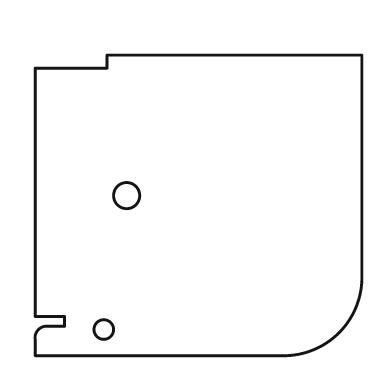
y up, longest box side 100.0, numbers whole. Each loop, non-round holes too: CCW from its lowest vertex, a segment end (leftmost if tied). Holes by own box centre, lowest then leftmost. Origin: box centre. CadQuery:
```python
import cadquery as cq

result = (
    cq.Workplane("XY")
    .moveTo(-50.0, -46.0)
    .lineTo(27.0, -46.0)
    .threePointArc((43.0, -39.0), (50.0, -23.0))
    .lineTo(50.0, 46.0)
    .lineTo(-28.0, 46.0)
    .lineTo(-28.0, 42.0)
    .lineTo(-50.0, 42.0)
    .lineTo(-50.0, -34.0)
    .lineTo(-41.0, -34.0)
    .lineTo(-41.0, -37.0)
    .lineTo(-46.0, -37.0)
    .threePointArc((-49.0, -38.0), (-50.0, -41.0))
    .close()
    .moveTo(-29.0, -38.0)
    .circle(3.0)
    .moveTo(-22.0, 3.0)
    .circle(4.0)
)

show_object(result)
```